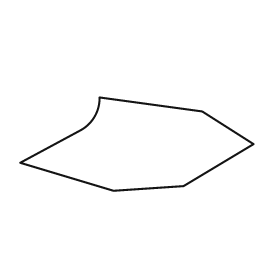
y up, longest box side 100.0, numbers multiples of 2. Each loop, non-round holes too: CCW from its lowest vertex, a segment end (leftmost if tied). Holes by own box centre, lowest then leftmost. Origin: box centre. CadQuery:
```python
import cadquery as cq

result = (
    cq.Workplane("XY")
    .moveTo(-10.0, -20.0)
    .lineTo(20.0, -18.0)
    .lineTo(50.0, 0.0)
    .lineTo(28.0, 14.0)
    .lineTo(-16.0, 20.0)
    .threePointArc((-18.0, 12.0), (-24.0, 6.0))
    .lineTo(-50.0, -8.0)
    .close()
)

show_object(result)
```